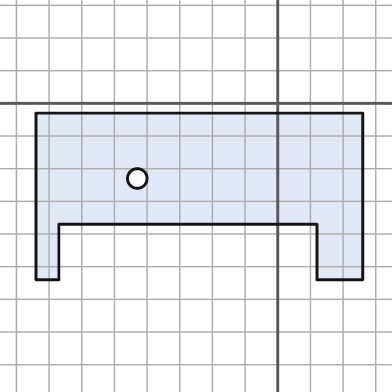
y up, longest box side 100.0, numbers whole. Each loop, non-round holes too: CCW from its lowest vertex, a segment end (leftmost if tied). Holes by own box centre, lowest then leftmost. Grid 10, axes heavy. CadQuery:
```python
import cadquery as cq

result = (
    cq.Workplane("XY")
    .moveTo(-74.0, -54.0)
    .lineTo(-67.0, -54.0)
    .lineTo(-67.0, -37.0)
    .lineTo(12.0, -37.0)
    .lineTo(12.0, -54.0)
    .lineTo(26.0, -54.0)
    .lineTo(26.0, -3.0)
    .lineTo(-74.0, -3.0)
    .close()
    .moveTo(-43.0, -23.0)
    .circle(3.0)
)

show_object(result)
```